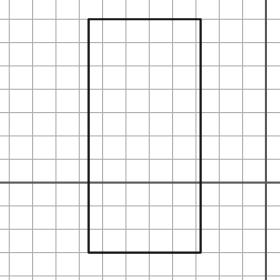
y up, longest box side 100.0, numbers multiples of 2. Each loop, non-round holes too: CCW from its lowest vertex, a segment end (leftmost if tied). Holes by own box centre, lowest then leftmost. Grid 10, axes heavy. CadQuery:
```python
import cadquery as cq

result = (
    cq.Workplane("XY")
    .moveTo(-76.0, -30.0)
    .lineTo(-28.0, -30.0)
    .lineTo(-28.0, 70.0)
    .lineTo(-76.0, 70.0)
    .close()
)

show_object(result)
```